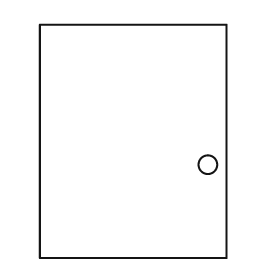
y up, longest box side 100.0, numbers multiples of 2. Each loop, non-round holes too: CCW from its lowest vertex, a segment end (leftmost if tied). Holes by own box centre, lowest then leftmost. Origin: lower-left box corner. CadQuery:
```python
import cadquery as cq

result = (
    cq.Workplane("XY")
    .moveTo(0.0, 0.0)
    .lineTo(80.0, 0.0)
    .lineTo(80.0, 100.0)
    .lineTo(0.0, 100.0)
    .close()
    .moveTo(72.0, 40.0)
    .circle(4.0)
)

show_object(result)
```